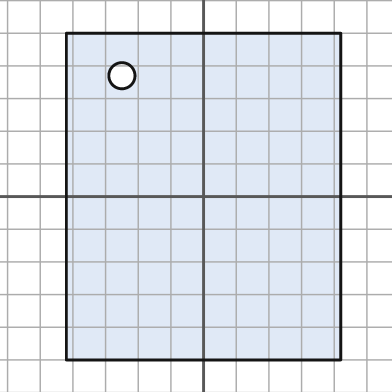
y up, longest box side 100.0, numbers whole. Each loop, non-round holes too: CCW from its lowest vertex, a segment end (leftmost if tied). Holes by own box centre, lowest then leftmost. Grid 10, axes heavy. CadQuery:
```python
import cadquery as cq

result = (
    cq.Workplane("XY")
    .moveTo(-42.0, -50.0)
    .lineTo(42.0, -50.0)
    .lineTo(42.0, 50.0)
    .lineTo(-42.0, 50.0)
    .close()
    .moveTo(-25.0, 37.0)
    .circle(4.0)
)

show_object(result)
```